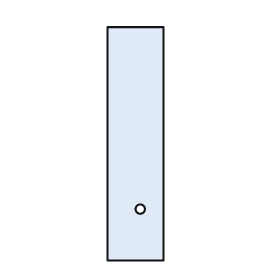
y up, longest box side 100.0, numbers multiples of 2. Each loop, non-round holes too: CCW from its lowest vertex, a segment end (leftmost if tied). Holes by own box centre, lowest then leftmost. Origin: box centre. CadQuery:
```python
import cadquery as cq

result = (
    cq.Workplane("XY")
    .moveTo(-12.0, -50.0)
    .lineTo(12.0, -50.0)
    .lineTo(12.0, 50.0)
    .lineTo(-12.0, 50.0)
    .close()
    .moveTo(2.0, -28.0)
    .circle(2.0)
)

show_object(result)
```